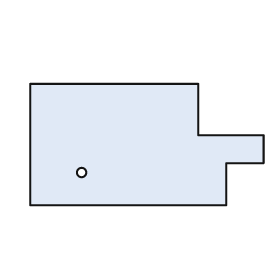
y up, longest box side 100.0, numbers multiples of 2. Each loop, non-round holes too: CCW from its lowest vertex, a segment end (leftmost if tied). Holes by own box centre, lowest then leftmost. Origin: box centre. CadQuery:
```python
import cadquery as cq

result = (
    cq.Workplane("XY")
    .moveTo(-50.0, -26.0)
    .lineTo(34.0, -26.0)
    .lineTo(34.0, -8.0)
    .lineTo(50.0, -8.0)
    .lineTo(50.0, 4.0)
    .lineTo(22.0, 4.0)
    .lineTo(22.0, 26.0)
    .lineTo(-50.0, 26.0)
    .close()
    .moveTo(-28.0, -12.0)
    .circle(2.0)
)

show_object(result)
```